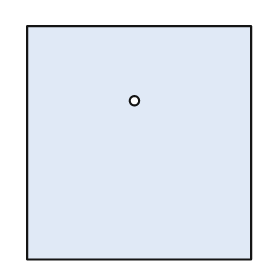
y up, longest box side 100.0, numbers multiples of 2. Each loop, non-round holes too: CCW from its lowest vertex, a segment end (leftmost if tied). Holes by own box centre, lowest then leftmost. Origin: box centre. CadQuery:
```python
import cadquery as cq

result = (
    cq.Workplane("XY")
    .moveTo(-48.0, -50.0)
    .lineTo(48.0, -50.0)
    .lineTo(48.0, 50.0)
    .lineTo(-48.0, 50.0)
    .close()
    .moveTo(-2.0, 18.0)
    .circle(2.0)
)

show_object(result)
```